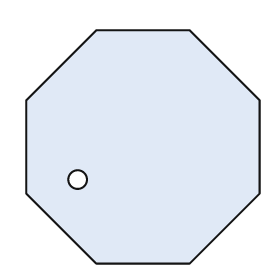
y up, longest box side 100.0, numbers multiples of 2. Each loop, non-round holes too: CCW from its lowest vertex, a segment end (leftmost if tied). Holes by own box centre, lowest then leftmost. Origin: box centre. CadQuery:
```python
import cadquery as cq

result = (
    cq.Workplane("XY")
    .moveTo(-20.0, -50.0)
    .lineTo(20.0, -50.0)
    .lineTo(50.0, -20.0)
    .lineTo(50.0, 20.0)
    .lineTo(20.0, 50.0)
    .lineTo(-20.0, 50.0)
    .lineTo(-50.0, 20.0)
    .lineTo(-50.0, -20.0)
    .close()
    .moveTo(-28.0, -14.0)
    .circle(4.0)
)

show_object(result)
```